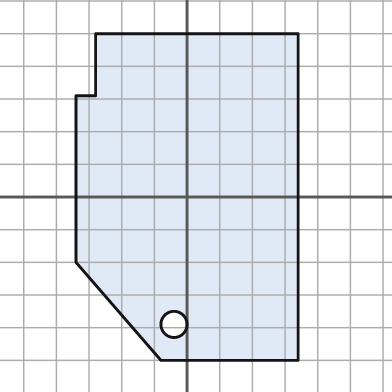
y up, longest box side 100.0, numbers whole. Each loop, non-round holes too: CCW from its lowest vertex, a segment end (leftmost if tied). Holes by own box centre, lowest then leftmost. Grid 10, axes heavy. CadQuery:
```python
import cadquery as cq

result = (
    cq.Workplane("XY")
    .moveTo(-8.0, -50.0)
    .lineTo(34.0, -50.0)
    .lineTo(34.0, 50.0)
    .lineTo(-28.0, 50.0)
    .lineTo(-28.0, 31.0)
    .lineTo(-34.0, 31.0)
    .lineTo(-34.0, -20.0)
    .close()
    .moveTo(-4.0, -39.0)
    .circle(4.0)
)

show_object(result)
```